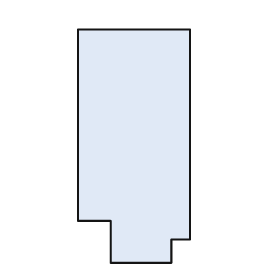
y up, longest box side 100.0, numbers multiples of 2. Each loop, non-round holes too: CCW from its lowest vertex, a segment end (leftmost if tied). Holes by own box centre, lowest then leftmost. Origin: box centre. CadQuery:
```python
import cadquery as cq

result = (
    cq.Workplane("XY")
    .moveTo(-10.0, -50.0)
    .lineTo(16.0, -50.0)
    .lineTo(16.0, -40.0)
    .lineTo(24.0, -40.0)
    .lineTo(24.0, 50.0)
    .lineTo(-24.0, 50.0)
    .lineTo(-24.0, -32.0)
    .lineTo(-10.0, -32.0)
    .close()
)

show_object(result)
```